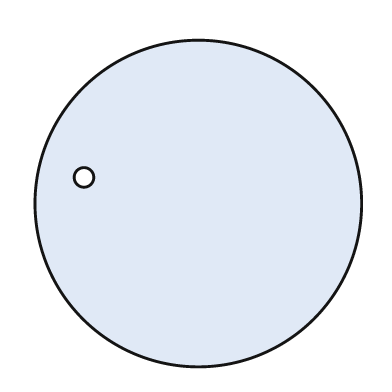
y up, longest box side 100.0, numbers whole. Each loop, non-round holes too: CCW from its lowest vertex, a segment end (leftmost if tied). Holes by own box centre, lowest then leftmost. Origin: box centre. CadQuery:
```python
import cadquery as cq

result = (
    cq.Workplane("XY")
    .moveTo(0.0, 0.0)
    .circle(50.0)
    .moveTo(-35.0, 8.0)
    .circle(3.0)
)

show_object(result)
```